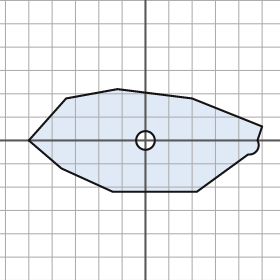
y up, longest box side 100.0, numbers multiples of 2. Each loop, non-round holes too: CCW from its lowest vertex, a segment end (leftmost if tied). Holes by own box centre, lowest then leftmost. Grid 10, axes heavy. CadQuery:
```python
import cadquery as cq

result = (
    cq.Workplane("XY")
    .moveTo(-14.0, -22.0)
    .lineTo(22.0, -22.0)
    .lineTo(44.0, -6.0)
    .threePointArc((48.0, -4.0), (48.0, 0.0))
    .lineTo(50.0, 6.0)
    .lineTo(20.0, 18.0)
    .lineTo(-12.0, 22.0)
    .lineTo(-34.0, 18.0)
    .lineTo(-50.0, 0.0)
    .lineTo(-36.0, -12.0)
    .close()
    .moveTo(0.0, 0.0)
    .circle(4.0)
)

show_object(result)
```